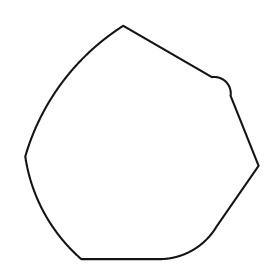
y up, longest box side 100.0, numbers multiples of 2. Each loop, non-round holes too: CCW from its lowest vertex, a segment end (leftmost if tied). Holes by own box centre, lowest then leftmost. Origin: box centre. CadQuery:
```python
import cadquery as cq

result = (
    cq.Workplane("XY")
    .moveTo(-26.0, -50.0)
    .lineTo(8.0, -50.0)
    .threePointArc((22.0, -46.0), (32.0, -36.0))
    .lineTo(50.0, -10.0)
    .lineTo(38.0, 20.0)
    .threePointArc((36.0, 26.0), (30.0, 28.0))
    .lineTo(-8.0, 50.0)
    .threePointArc((-34.0, 26.0), (-50.0, -6.0))
    .threePointArc((-42.0, -30.0), (-26.0, -50.0))
    .close()
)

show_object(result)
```